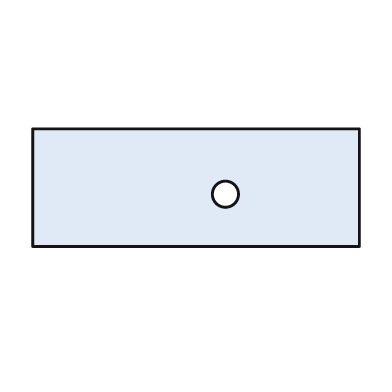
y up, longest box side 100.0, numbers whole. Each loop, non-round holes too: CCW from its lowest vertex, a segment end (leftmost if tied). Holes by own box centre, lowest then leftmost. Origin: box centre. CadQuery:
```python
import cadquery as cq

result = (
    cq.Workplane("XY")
    .moveTo(-50.0, -18.0)
    .lineTo(50.0, -18.0)
    .lineTo(50.0, 18.0)
    .lineTo(-50.0, 18.0)
    .close()
    .moveTo(9.0, -2.0)
    .circle(4.0)
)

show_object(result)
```